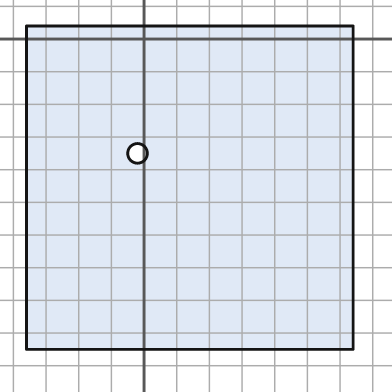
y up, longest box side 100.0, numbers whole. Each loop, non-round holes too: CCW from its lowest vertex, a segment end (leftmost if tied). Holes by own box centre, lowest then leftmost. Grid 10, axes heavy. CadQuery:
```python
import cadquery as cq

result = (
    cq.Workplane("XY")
    .moveTo(-36.0, -95.0)
    .lineTo(64.0, -95.0)
    .lineTo(64.0, 4.0)
    .lineTo(-36.0, 4.0)
    .close()
    .moveTo(-2.0, -35.0)
    .circle(3.0)
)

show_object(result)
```